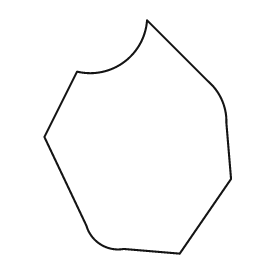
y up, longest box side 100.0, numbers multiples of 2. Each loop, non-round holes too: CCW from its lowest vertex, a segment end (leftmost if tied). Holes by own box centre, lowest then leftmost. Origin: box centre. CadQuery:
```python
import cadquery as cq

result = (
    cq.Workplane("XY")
    .moveTo(18.0, -50.0)
    .lineTo(40.0, -18.0)
    .lineTo(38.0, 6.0)
    .threePointArc((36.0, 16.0), (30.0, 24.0))
    .lineTo(4.0, 50.0)
    .threePointArc((-6.0, 32.0), (-26.0, 28.0))
    .lineTo(-40.0, 0.0)
    .lineTo(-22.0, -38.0)
    .threePointArc((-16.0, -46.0), (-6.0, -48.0))
    .close()
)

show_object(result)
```